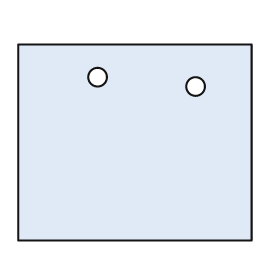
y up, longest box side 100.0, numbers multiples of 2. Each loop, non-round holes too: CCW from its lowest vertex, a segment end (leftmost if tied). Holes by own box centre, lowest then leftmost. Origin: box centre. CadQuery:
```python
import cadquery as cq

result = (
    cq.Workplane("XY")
    .moveTo(-50.0, -42.0)
    .lineTo(50.0, -42.0)
    .lineTo(50.0, 42.0)
    .lineTo(-50.0, 42.0)
    .close()
    .moveTo(26.0, 24.0)
    .circle(4.0)
    .moveTo(-16.0, 28.0)
    .circle(4.0)
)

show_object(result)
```